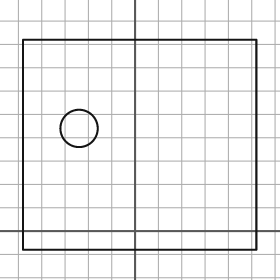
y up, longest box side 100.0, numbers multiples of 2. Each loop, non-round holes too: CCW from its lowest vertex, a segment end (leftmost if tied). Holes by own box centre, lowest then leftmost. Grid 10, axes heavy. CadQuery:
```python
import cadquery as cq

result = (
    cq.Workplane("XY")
    .moveTo(-48.0, -8.0)
    .lineTo(52.0, -8.0)
    .lineTo(52.0, 82.0)
    .lineTo(-48.0, 82.0)
    .close()
    .moveTo(-24.0, 44.0)
    .circle(8.0)
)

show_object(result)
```